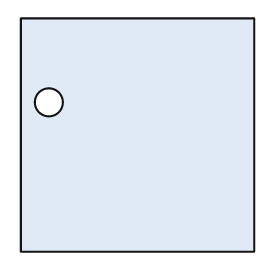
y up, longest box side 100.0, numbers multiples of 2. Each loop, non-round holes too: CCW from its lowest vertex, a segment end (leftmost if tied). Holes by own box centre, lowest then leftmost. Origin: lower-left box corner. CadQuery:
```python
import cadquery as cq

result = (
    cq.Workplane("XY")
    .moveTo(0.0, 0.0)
    .lineTo(100.0, 0.0)
    .lineTo(100.0, 100.0)
    .lineTo(0.0, 100.0)
    .close()
    .moveTo(12.0, 64.0)
    .circle(6.0)
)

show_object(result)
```